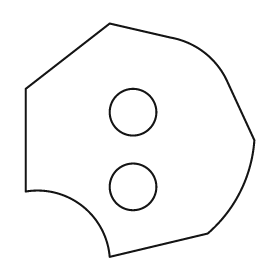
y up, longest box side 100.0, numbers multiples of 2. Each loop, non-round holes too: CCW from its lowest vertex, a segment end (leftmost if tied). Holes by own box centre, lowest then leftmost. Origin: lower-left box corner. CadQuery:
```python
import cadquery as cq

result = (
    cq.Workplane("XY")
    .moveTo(36.0, 0.0)
    .lineTo(78.0, 10.0)
    .threePointArc((92.0, 28.0), (98.0, 50.0))
    .lineTo(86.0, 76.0)
    .threePointArc((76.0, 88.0), (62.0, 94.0))
    .lineTo(36.0, 100.0)
    .lineTo(0.0, 72.0)
    .lineTo(0.0, 28.0)
    .threePointArc((24.0, 22.0), (36.0, 0.0))
    .close()
    .moveTo(46.0, 30.0)
    .circle(10.0)
    .moveTo(46.0, 62.0)
    .circle(10.0)
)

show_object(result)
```